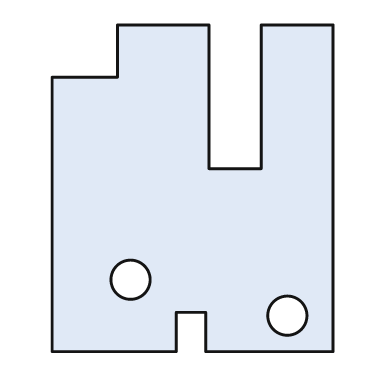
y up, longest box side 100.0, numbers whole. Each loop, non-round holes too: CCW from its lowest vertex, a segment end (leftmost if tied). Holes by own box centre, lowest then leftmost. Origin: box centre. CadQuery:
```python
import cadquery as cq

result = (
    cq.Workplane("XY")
    .moveTo(-43.0, -50.0)
    .lineTo(-5.0, -50.0)
    .lineTo(-5.0, -38.0)
    .lineTo(4.0, -38.0)
    .lineTo(4.0, -50.0)
    .lineTo(43.0, -50.0)
    .lineTo(43.0, 50.0)
    .lineTo(21.0, 50.0)
    .lineTo(21.0, 6.0)
    .lineTo(5.0, 6.0)
    .lineTo(5.0, 50.0)
    .lineTo(-23.0, 50.0)
    .lineTo(-23.0, 34.0)
    .lineTo(-43.0, 34.0)
    .close()
    .moveTo(29.0, -39.0)
    .circle(6.0)
    .moveTo(-19.0, -28.0)
    .circle(6.0)
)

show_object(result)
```